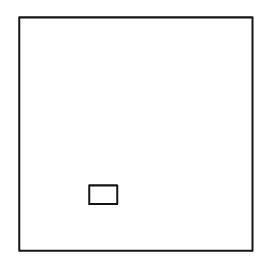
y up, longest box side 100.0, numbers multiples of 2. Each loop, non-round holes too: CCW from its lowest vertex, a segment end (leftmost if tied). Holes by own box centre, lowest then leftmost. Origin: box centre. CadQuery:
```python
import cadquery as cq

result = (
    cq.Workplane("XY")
    .moveTo(-50.0, -50.0)
    .lineTo(50.0, -50.0)
    .lineTo(50.0, 50.0)
    .lineTo(-50.0, 50.0)
    .close()
    .moveTo(-20.0, -30.0)
    .lineTo(-8.0, -30.0)
    .lineTo(-8.0, -22.0)
    .lineTo(-20.0, -22.0)
    .close()
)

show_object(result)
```